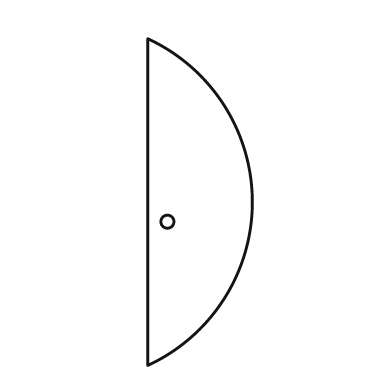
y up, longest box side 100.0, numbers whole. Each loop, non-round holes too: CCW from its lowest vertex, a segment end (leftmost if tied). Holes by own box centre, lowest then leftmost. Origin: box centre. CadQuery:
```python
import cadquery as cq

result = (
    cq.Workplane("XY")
    .moveTo(-16.0, -50.0)
    .threePointArc((16.0, 0.0), (-16.0, 50.0))
    .close()
    .moveTo(-10.0, -6.0)
    .circle(2.0)
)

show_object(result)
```